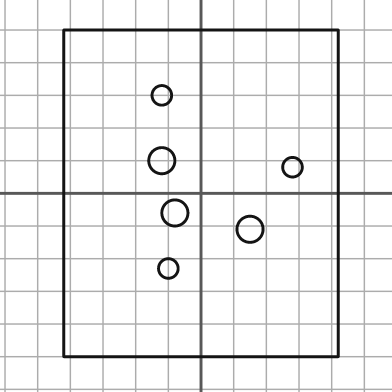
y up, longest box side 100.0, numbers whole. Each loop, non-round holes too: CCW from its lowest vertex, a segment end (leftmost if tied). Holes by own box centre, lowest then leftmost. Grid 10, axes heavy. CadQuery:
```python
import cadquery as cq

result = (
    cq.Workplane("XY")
    .moveTo(-42.0, -50.0)
    .lineTo(42.0, -50.0)
    .lineTo(42.0, 50.0)
    .lineTo(-42.0, 50.0)
    .close()
    .moveTo(-10.0, -23.0)
    .circle(3.0)
    .moveTo(15.0, -11.0)
    .circle(4.0)
    .moveTo(-8.0, -6.0)
    .circle(4.0)
    .moveTo(28.0, 8.0)
    .circle(3.0)
    .moveTo(-12.0, 10.0)
    .circle(4.0)
    .moveTo(-12.0, 30.0)
    .circle(3.0)
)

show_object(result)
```